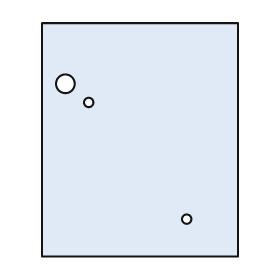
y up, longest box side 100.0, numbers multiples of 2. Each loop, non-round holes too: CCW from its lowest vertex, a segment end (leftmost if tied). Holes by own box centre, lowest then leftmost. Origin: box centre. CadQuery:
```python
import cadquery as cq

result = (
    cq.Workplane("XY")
    .moveTo(-42.0, -50.0)
    .lineTo(42.0, -50.0)
    .lineTo(42.0, 50.0)
    .lineTo(-42.0, 50.0)
    .close()
    .moveTo(20.0, -34.0)
    .circle(2.0)
    .moveTo(-22.0, 16.0)
    .circle(2.0)
    .moveTo(-32.0, 24.0)
    .circle(4.0)
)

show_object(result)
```